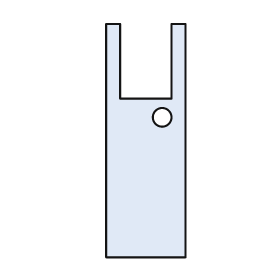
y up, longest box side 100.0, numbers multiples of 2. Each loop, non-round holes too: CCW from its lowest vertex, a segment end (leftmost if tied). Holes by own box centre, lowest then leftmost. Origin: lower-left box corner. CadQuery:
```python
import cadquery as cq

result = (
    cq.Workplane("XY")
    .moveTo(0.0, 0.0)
    .lineTo(34.0, 0.0)
    .lineTo(34.0, 100.0)
    .lineTo(28.0, 100.0)
    .lineTo(28.0, 68.0)
    .lineTo(6.0, 68.0)
    .lineTo(6.0, 100.0)
    .lineTo(0.0, 100.0)
    .close()
    .moveTo(24.0, 60.0)
    .circle(4.0)
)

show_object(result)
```